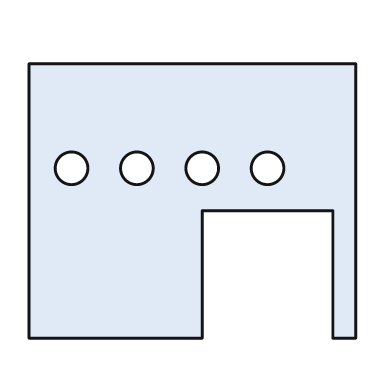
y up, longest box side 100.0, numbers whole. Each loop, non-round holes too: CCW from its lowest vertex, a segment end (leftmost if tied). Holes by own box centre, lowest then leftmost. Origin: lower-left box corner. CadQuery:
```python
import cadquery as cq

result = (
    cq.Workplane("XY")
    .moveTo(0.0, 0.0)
    .lineTo(53.0, 0.0)
    .lineTo(53.0, 39.0)
    .lineTo(93.0, 39.0)
    .lineTo(93.0, 0.0)
    .lineTo(100.0, 0.0)
    .lineTo(100.0, 84.0)
    .lineTo(0.0, 84.0)
    .close()
    .moveTo(13.0, 52.0)
    .circle(5.0)
    .moveTo(33.0, 52.0)
    .circle(5.0)
    .moveTo(53.0, 52.0)
    .circle(5.0)
    .moveTo(73.0, 52.0)
    .circle(5.0)
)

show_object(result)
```